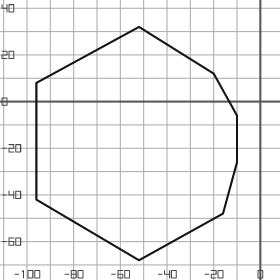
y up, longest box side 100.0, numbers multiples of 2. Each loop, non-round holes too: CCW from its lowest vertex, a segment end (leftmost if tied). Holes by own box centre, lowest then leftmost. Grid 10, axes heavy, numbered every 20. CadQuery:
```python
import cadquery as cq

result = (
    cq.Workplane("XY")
    .moveTo(-52.0, -68.0)
    .lineTo(-16.0, -48.0)
    .lineTo(-10.0, -26.0)
    .lineTo(-10.0, -6.0)
    .lineTo(-20.0, 12.0)
    .lineTo(-52.0, 32.0)
    .lineTo(-96.0, 8.0)
    .lineTo(-96.0, -42.0)
    .close()
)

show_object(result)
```